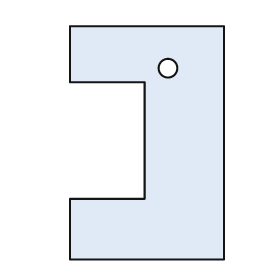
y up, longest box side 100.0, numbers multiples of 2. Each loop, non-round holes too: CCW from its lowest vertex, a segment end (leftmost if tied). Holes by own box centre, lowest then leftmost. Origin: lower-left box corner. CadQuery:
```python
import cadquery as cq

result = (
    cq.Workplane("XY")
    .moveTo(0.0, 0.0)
    .lineTo(66.0, 0.0)
    .lineTo(66.0, 100.0)
    .lineTo(0.0, 100.0)
    .lineTo(0.0, 76.0)
    .lineTo(32.0, 76.0)
    .lineTo(32.0, 26.0)
    .lineTo(0.0, 26.0)
    .close()
    .moveTo(42.0, 82.0)
    .circle(4.0)
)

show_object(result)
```